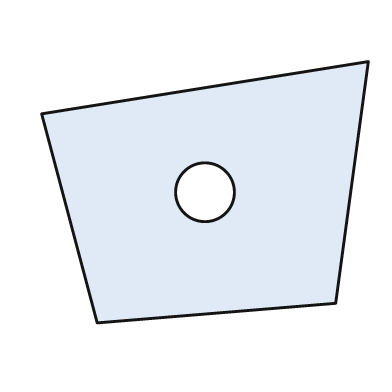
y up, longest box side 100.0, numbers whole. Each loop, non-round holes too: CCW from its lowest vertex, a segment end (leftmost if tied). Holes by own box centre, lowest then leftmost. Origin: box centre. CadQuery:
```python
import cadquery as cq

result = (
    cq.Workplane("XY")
    .moveTo(-33.0, -40.0)
    .lineTo(40.0, -34.0)
    .lineTo(50.0, 40.0)
    .lineTo(-50.0, 24.0)
    .close()
    .moveTo(0.0, 0.0)
    .circle(9.0)
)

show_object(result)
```